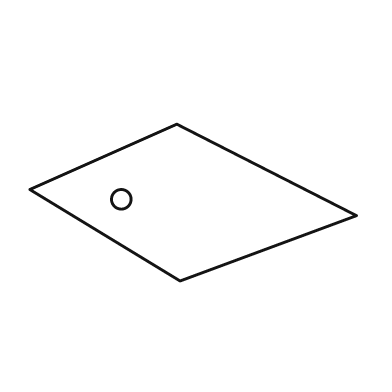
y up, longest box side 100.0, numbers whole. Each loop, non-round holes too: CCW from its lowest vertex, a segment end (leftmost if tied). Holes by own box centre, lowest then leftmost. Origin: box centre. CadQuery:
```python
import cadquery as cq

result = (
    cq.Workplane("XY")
    .moveTo(-4.0, -24.0)
    .lineTo(50.0, -4.0)
    .lineTo(-5.0, 24.0)
    .lineTo(-50.0, 4.0)
    .close()
    .moveTo(-22.0, 1.0)
    .circle(3.0)
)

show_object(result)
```